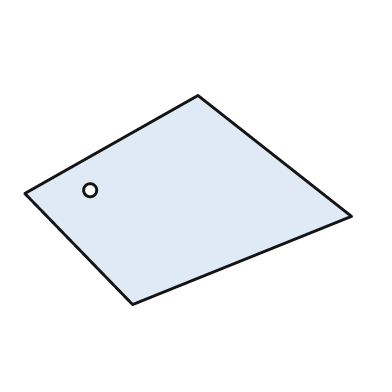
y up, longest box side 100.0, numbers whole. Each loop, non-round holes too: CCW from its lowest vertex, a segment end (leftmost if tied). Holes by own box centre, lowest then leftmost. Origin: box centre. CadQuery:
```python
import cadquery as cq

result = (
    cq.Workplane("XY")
    .moveTo(-17.0, -32.0)
    .lineTo(50.0, -5.0)
    .lineTo(3.0, 32.0)
    .lineTo(-50.0, 2.0)
    .close()
    .moveTo(-30.0, 3.0)
    .circle(2.0)
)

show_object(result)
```